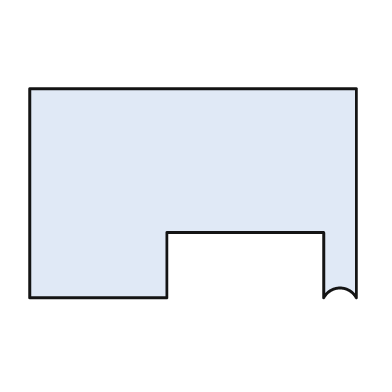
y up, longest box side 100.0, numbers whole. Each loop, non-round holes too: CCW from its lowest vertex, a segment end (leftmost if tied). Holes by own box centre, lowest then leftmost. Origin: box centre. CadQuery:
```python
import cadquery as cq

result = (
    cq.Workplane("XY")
    .moveTo(-50.0, -32.0)
    .lineTo(-8.0, -32.0)
    .lineTo(-8.0, -12.0)
    .lineTo(40.0, -12.0)
    .lineTo(40.0, -32.0)
    .threePointArc((45.0, -29.0), (50.0, -32.0))
    .lineTo(50.0, 32.0)
    .lineTo(-50.0, 32.0)
    .close()
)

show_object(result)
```